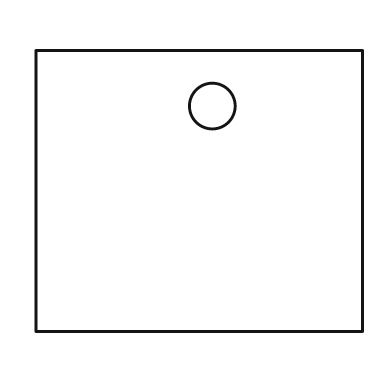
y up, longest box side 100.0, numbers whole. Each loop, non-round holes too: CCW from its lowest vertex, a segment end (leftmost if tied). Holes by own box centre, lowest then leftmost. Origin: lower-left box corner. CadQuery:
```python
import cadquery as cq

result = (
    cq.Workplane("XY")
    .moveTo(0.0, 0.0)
    .lineTo(100.0, 0.0)
    .lineTo(100.0, 86.0)
    .lineTo(0.0, 86.0)
    .close()
    .moveTo(54.0, 69.0)
    .circle(7.0)
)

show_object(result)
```